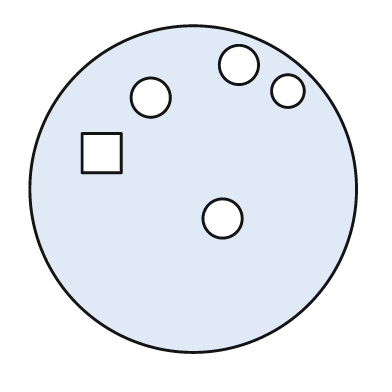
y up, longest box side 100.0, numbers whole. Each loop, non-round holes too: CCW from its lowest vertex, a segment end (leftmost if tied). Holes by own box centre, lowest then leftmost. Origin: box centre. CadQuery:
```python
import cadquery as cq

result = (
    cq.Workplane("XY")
    .moveTo(0.0, 0.0)
    .circle(50.0)
    .moveTo(9.0, -9.0)
    .circle(6.0)
    .moveTo(-34.0, 5.0)
    .lineTo(-22.0, 5.0)
    .lineTo(-22.0, 17.0)
    .lineTo(-34.0, 17.0)
    .close()
    .moveTo(-13.0, 28.0)
    .circle(6.0)
    .moveTo(29.0, 30.0)
    .circle(5.0)
    .moveTo(14.0, 38.0)
    .circle(6.0)
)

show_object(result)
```